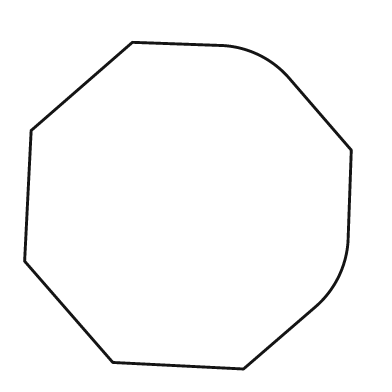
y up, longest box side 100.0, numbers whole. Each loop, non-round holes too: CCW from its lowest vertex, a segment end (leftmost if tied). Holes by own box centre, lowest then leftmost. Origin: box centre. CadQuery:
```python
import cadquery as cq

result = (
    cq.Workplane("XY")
    .moveTo(17.0, -50.0)
    .lineTo(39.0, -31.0)
    .threePointArc((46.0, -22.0), (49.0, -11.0))
    .lineTo(50.0, 17.0)
    .lineTo(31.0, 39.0)
    .threePointArc((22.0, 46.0), (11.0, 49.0))
    .lineTo(-17.0, 50.0)
    .lineTo(-48.0, 23.0)
    .lineTo(-50.0, -17.0)
    .lineTo(-23.0, -48.0)
    .close()
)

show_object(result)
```